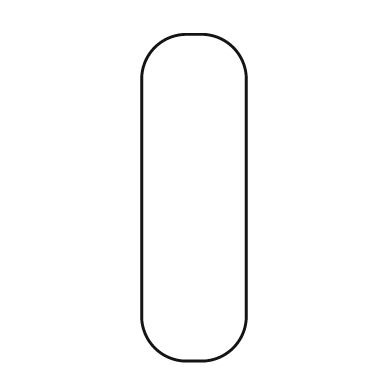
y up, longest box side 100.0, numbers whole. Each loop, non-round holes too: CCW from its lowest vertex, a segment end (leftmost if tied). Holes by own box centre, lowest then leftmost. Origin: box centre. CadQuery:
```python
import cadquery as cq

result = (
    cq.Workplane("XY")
    .moveTo(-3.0, -50.0)
    .lineTo(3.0, -50.0)
    .threePointArc((12.0, -46.0), (16.0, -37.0))
    .lineTo(16.0, 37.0)
    .threePointArc((12.0, 46.0), (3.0, 50.0))
    .lineTo(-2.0, 50.0)
    .threePointArc((-12.0, 46.0), (-16.0, 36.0))
    .lineTo(-16.0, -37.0)
    .threePointArc((-12.0, -46.0), (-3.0, -50.0))
    .close()
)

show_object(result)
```